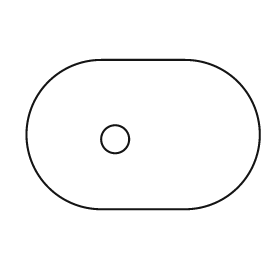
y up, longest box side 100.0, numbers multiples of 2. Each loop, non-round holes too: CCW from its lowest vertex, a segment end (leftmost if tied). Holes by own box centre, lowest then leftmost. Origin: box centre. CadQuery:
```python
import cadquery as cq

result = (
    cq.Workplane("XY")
    .moveTo(-18.0, -32.0)
    .lineTo(18.0, -32.0)
    .threePointArc((50.0, 0.0), (18.0, 32.0))
    .lineTo(-18.0, 32.0)
    .threePointArc((-50.0, 0.0), (-18.0, -32.0))
    .close()
    .moveTo(-12.0, -2.0)
    .circle(6.0)
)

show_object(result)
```